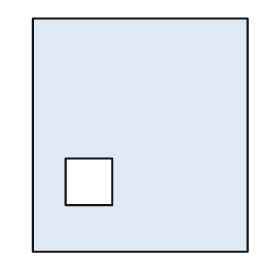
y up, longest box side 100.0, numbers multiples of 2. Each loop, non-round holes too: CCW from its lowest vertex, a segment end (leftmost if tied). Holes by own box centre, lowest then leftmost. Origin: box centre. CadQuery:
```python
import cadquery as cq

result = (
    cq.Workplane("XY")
    .moveTo(-46.0, -50.0)
    .lineTo(46.0, -50.0)
    .lineTo(46.0, 50.0)
    .lineTo(-46.0, 50.0)
    .close()
    .moveTo(-32.0, -30.0)
    .lineTo(-12.0, -30.0)
    .lineTo(-12.0, -10.0)
    .lineTo(-32.0, -10.0)
    .close()
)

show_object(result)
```